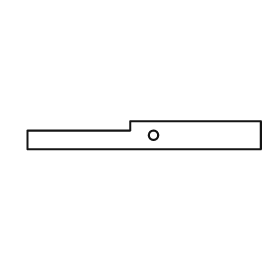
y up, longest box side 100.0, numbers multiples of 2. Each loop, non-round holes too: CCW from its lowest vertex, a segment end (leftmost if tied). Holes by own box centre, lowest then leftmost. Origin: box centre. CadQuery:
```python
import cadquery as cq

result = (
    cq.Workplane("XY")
    .moveTo(-50.0, -6.0)
    .lineTo(50.0, -6.0)
    .lineTo(50.0, 6.0)
    .lineTo(-6.0, 6.0)
    .lineTo(-6.0, 2.0)
    .lineTo(-50.0, 2.0)
    .close()
    .moveTo(4.0, 0.0)
    .circle(2.0)
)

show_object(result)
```